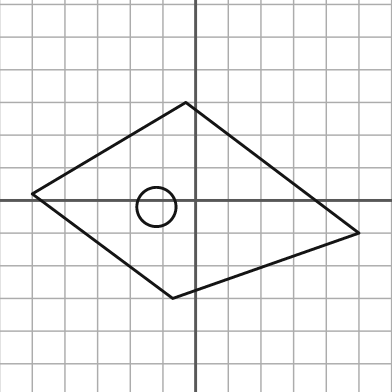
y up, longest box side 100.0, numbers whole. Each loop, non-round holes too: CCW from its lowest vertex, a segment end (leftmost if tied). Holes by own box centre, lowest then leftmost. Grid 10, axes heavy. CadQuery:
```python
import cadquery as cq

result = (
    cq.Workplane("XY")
    .moveTo(-7.0, -30.0)
    .lineTo(50.0, -10.0)
    .lineTo(-3.0, 30.0)
    .lineTo(-50.0, 2.0)
    .close()
    .moveTo(-12.0, -2.0)
    .circle(6.0)
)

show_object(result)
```